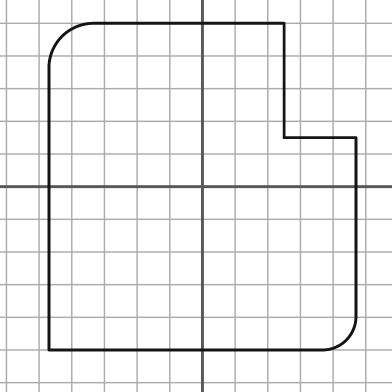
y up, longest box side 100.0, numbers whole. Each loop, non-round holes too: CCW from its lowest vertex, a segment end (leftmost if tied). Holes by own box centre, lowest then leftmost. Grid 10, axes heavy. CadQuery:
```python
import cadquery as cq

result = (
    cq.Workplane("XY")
    .moveTo(-47.0, -50.0)
    .lineTo(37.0, -50.0)
    .threePointArc((44.0, -47.0), (47.0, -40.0))
    .lineTo(47.0, 15.0)
    .lineTo(25.0, 15.0)
    .lineTo(25.0, 50.0)
    .lineTo(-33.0, 50.0)
    .threePointArc((-43.0, 46.0), (-47.0, 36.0))
    .close()
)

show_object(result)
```